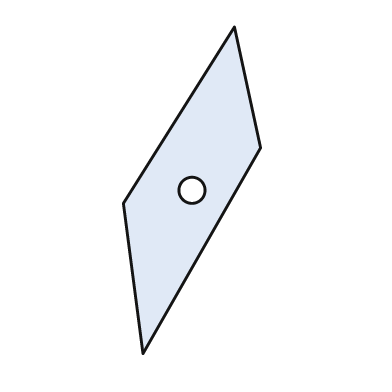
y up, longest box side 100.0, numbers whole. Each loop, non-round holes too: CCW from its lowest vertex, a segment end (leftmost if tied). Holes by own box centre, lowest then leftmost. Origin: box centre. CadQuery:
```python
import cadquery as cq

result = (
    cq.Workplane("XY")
    .moveTo(-15.0, -50.0)
    .lineTo(21.0, 13.0)
    .lineTo(13.0, 50.0)
    .lineTo(-21.0, -4.0)
    .close()
    .moveTo(0.0, 0.0)
    .circle(4.0)
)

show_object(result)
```